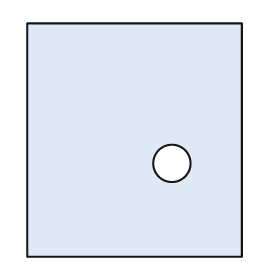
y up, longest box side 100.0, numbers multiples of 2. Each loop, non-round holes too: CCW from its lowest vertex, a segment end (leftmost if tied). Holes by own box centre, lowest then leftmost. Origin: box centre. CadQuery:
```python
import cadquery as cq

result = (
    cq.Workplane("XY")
    .moveTo(-46.0, -50.0)
    .lineTo(46.0, -50.0)
    .lineTo(46.0, 50.0)
    .lineTo(-46.0, 50.0)
    .close()
    .moveTo(16.0, -10.0)
    .circle(8.0)
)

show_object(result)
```